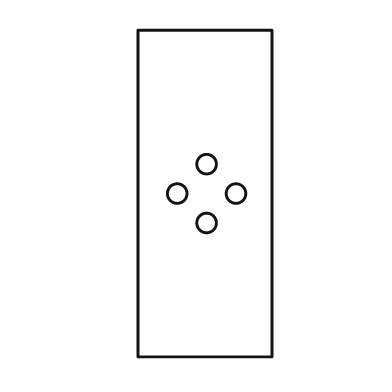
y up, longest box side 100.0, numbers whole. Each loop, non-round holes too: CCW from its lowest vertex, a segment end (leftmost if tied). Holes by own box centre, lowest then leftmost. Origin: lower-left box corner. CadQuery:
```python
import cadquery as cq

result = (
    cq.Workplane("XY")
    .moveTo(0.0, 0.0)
    .lineTo(41.0, 0.0)
    .lineTo(41.0, 100.0)
    .lineTo(0.0, 100.0)
    .close()
    .moveTo(21.0, 41.0)
    .circle(3.0)
    .moveTo(12.0, 50.0)
    .circle(3.0)
    .moveTo(30.0, 50.0)
    .circle(3.0)
    .moveTo(21.0, 59.0)
    .circle(3.0)
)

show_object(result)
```